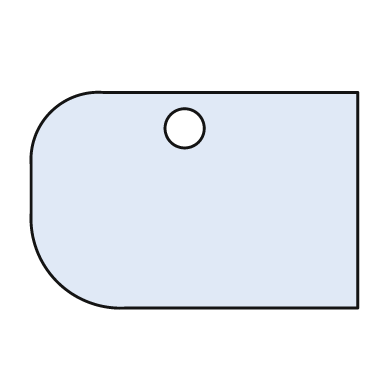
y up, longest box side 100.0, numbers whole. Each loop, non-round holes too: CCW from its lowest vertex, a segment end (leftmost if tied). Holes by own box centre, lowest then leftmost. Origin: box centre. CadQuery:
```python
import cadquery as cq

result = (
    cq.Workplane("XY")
    .moveTo(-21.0, -33.0)
    .lineTo(50.0, -33.0)
    .lineTo(50.0, 33.0)
    .lineTo(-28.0, 33.0)
    .threePointArc((-44.0, 27.0), (-50.0, 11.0))
    .lineTo(-50.0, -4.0)
    .threePointArc((-42.0, -25.0), (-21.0, -33.0))
    .close()
    .moveTo(-3.0, 22.0)
    .circle(6.0)
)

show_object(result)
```